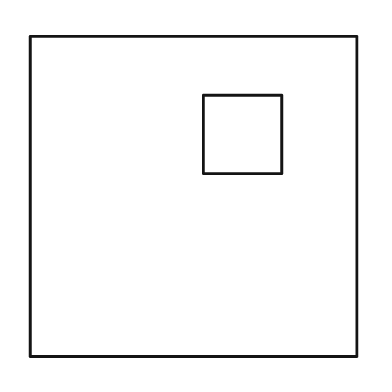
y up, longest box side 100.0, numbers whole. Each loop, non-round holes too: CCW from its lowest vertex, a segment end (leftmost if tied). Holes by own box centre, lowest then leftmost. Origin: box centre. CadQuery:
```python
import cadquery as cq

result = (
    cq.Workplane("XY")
    .moveTo(-50.0, -49.0)
    .lineTo(50.0, -49.0)
    .lineTo(50.0, 49.0)
    .lineTo(-50.0, 49.0)
    .close()
    .moveTo(3.0, 7.0)
    .lineTo(27.0, 7.0)
    .lineTo(27.0, 31.0)
    .lineTo(3.0, 31.0)
    .close()
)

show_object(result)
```